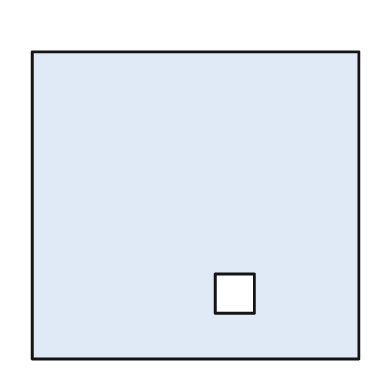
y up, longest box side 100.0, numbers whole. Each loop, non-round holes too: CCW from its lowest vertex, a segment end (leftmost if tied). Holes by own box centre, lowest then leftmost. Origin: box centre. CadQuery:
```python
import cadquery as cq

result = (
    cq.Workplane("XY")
    .moveTo(-50.0, -47.0)
    .lineTo(50.0, -47.0)
    .lineTo(50.0, 47.0)
    .lineTo(-50.0, 47.0)
    .close()
    .moveTo(6.0, -33.0)
    .lineTo(18.0, -33.0)
    .lineTo(18.0, -21.0)
    .lineTo(6.0, -21.0)
    .close()
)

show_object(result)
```